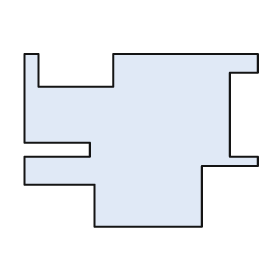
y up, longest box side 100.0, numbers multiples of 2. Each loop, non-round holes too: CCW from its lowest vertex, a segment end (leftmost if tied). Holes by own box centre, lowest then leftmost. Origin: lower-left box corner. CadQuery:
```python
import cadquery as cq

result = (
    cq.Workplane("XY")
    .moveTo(30.0, 0.0)
    .lineTo(76.0, 0.0)
    .lineTo(76.0, 26.0)
    .lineTo(100.0, 26.0)
    .lineTo(100.0, 30.0)
    .lineTo(88.0, 30.0)
    .lineTo(88.0, 66.0)
    .lineTo(100.0, 66.0)
    .lineTo(100.0, 74.0)
    .lineTo(38.0, 74.0)
    .lineTo(38.0, 60.0)
    .lineTo(6.0, 60.0)
    .lineTo(6.0, 74.0)
    .lineTo(0.0, 74.0)
    .lineTo(0.0, 36.0)
    .lineTo(28.0, 36.0)
    .lineTo(28.0, 30.0)
    .lineTo(0.0, 30.0)
    .lineTo(0.0, 18.0)
    .lineTo(30.0, 18.0)
    .close()
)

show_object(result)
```